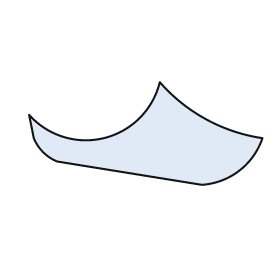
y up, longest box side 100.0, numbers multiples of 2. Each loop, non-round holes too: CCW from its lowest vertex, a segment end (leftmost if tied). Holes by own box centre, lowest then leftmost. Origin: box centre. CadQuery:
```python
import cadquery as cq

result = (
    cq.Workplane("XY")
    .moveTo(24.0, -22.0)
    .threePointArc((40.0, -16.0), (50.0, -2.0))
    .threePointArc((26.0, 6.0), (6.0, 22.0))
    .threePointArc((-18.0, -2.0), (-50.0, 8.0))
    .lineTo(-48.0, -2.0)
    .threePointArc((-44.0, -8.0), (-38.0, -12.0))
    .close()
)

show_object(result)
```